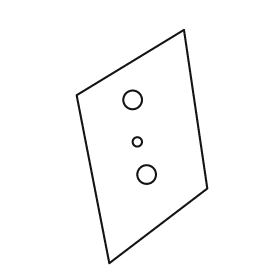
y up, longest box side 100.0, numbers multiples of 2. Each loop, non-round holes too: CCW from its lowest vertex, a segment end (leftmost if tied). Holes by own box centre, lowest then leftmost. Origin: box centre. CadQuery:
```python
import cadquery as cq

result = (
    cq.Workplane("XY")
    .moveTo(-14.0, -50.0)
    .lineTo(28.0, -18.0)
    .lineTo(18.0, 50.0)
    .lineTo(-28.0, 22.0)
    .close()
    .moveTo(2.0, -12.0)
    .circle(4.0)
    .moveTo(-2.0, 2.0)
    .circle(2.0)
    .moveTo(-4.0, 20.0)
    .circle(4.0)
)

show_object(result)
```